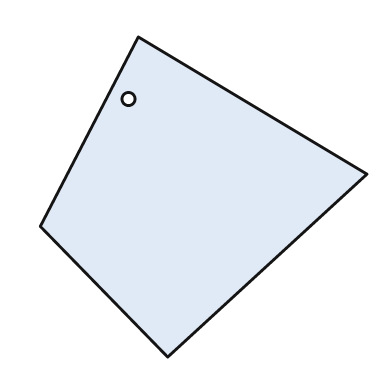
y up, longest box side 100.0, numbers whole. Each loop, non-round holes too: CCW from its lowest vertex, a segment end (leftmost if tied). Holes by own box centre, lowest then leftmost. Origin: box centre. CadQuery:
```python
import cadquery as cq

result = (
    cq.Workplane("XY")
    .moveTo(-11.0, -49.0)
    .lineTo(50.0, 7.0)
    .lineTo(-20.0, 49.0)
    .lineTo(-50.0, -9.0)
    .close()
    .moveTo(-23.0, 30.0)
    .circle(2.0)
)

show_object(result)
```